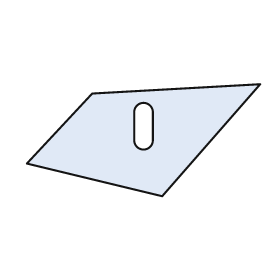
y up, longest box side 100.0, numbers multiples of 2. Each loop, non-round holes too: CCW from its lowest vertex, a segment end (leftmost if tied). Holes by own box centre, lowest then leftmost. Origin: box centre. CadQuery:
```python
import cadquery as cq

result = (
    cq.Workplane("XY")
    .moveTo(8.0, -24.0)
    .lineTo(50.0, 24.0)
    .lineTo(-22.0, 20.0)
    .lineTo(-50.0, -10.0)
    .close()
    .moveTo(-4.0, 0.0)
    .threePointArc((0.0, -4.0), (4.0, 0.0))
    .lineTo(4.0, 12.0)
    .threePointArc((0.0, 16.0), (-4.0, 12.0))
    .close()
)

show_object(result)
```